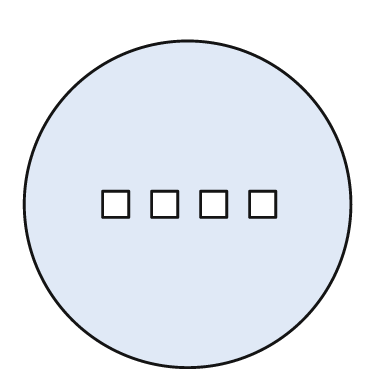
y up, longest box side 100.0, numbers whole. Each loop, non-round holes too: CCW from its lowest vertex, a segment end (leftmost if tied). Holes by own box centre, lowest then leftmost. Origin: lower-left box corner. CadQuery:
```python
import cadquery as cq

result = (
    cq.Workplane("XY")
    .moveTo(50.0, 50.0)
    .circle(50.0)
    .moveTo(24.0, 46.0)
    .lineTo(32.0, 46.0)
    .lineTo(32.0, 54.0)
    .lineTo(24.0, 54.0)
    .close()
    .moveTo(39.0, 46.0)
    .lineTo(47.0, 46.0)
    .lineTo(47.0, 54.0)
    .lineTo(39.0, 54.0)
    .close()
    .moveTo(54.0, 46.0)
    .lineTo(62.0, 46.0)
    .lineTo(62.0, 54.0)
    .lineTo(54.0, 54.0)
    .close()
    .moveTo(69.0, 46.0)
    .lineTo(77.0, 46.0)
    .lineTo(77.0, 54.0)
    .lineTo(69.0, 54.0)
    .close()
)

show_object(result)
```